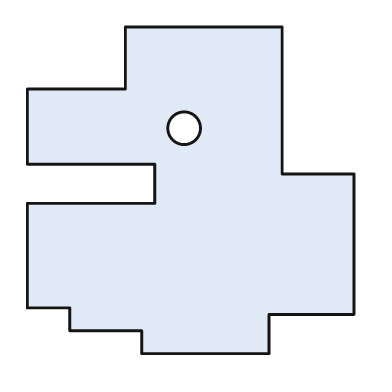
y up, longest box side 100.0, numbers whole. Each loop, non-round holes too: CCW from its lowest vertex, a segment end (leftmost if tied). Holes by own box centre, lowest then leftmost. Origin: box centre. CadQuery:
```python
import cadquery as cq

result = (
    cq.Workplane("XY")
    .moveTo(-15.0, -50.0)
    .lineTo(24.0, -50.0)
    .lineTo(24.0, -38.0)
    .lineTo(50.0, -38.0)
    .lineTo(50.0, 5.0)
    .lineTo(28.0, 5.0)
    .lineTo(28.0, 50.0)
    .lineTo(-20.0, 50.0)
    .lineTo(-20.0, 31.0)
    .lineTo(-50.0, 31.0)
    .lineTo(-50.0, 8.0)
    .lineTo(-11.0, 8.0)
    .lineTo(-11.0, -4.0)
    .lineTo(-50.0, -4.0)
    .lineTo(-50.0, -36.0)
    .lineTo(-37.0, -36.0)
    .lineTo(-37.0, -43.0)
    .lineTo(-15.0, -43.0)
    .close()
    .moveTo(-2.0, 19.0)
    .circle(5.0)
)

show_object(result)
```